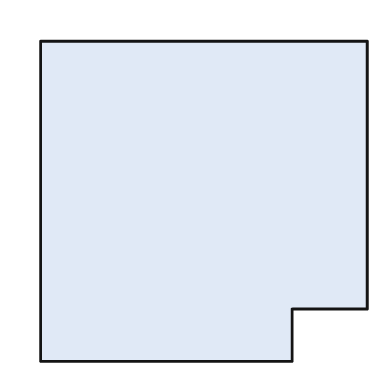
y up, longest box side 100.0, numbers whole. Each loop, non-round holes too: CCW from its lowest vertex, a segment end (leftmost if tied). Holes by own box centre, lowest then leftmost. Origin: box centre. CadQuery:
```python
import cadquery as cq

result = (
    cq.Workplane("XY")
    .moveTo(-50.0, -49.0)
    .lineTo(27.0, -49.0)
    .lineTo(27.0, -33.0)
    .lineTo(50.0, -33.0)
    .lineTo(50.0, 49.0)
    .lineTo(-50.0, 49.0)
    .close()
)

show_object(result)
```